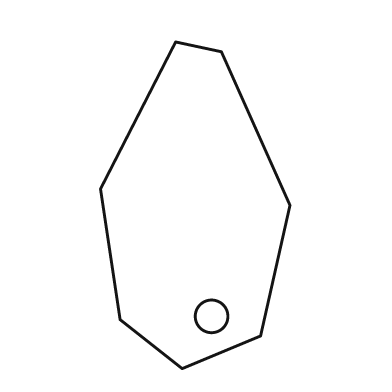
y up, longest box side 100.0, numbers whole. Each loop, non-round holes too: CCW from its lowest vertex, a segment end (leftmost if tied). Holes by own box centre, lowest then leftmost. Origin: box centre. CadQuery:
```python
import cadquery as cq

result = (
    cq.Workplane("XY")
    .moveTo(-4.0, -50.0)
    .lineTo(20.0, -40.0)
    .lineTo(29.0, 0.0)
    .lineTo(8.0, 47.0)
    .lineTo(-6.0, 50.0)
    .lineTo(-29.0, 5.0)
    .lineTo(-23.0, -35.0)
    .close()
    .moveTo(5.0, -34.0)
    .circle(5.0)
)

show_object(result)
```